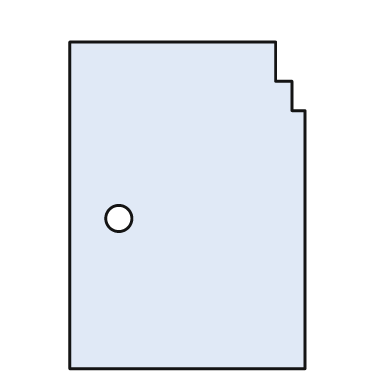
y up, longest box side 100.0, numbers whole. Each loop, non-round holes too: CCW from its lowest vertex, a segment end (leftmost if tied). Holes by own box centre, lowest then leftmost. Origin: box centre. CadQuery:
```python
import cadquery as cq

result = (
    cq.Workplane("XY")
    .moveTo(-36.0, -50.0)
    .lineTo(36.0, -50.0)
    .lineTo(36.0, 29.0)
    .lineTo(32.0, 29.0)
    .lineTo(32.0, 38.0)
    .lineTo(27.0, 38.0)
    .lineTo(27.0, 50.0)
    .lineTo(-36.0, 50.0)
    .close()
    .moveTo(-21.0, -4.0)
    .circle(4.0)
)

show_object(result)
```